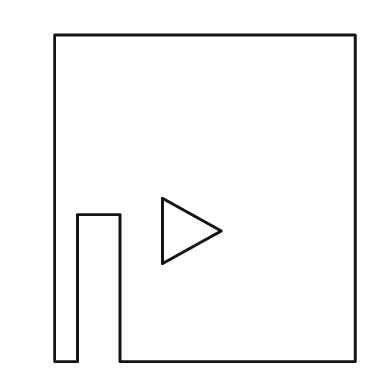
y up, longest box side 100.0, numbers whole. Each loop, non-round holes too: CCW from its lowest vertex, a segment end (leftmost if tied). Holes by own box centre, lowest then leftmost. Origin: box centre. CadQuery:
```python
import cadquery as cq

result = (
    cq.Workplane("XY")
    .moveTo(-46.0, -50.0)
    .lineTo(-39.0, -50.0)
    .lineTo(-39.0, -5.0)
    .lineTo(-26.0, -5.0)
    .lineTo(-26.0, -50.0)
    .lineTo(46.0, -50.0)
    .lineTo(46.0, 50.0)
    .lineTo(-46.0, 50.0)
    .close()
    .moveTo(-13.0, -20.0)
    .lineTo(5.0, -10.0)
    .lineTo(-13.0, 0.0)
    .close()
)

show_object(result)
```